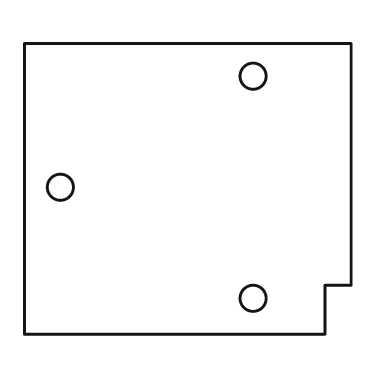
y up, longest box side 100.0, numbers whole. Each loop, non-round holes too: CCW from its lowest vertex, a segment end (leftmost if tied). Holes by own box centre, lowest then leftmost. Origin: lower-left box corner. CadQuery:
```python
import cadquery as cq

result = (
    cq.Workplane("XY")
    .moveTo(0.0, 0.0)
    .lineTo(92.0, 0.0)
    .lineTo(92.0, 15.0)
    .lineTo(100.0, 15.0)
    .lineTo(100.0, 89.0)
    .lineTo(0.0, 89.0)
    .close()
    .moveTo(70.0, 11.0)
    .circle(4.0)
    .moveTo(11.0, 45.0)
    .circle(4.0)
    .moveTo(70.0, 79.0)
    .circle(4.0)
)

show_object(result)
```